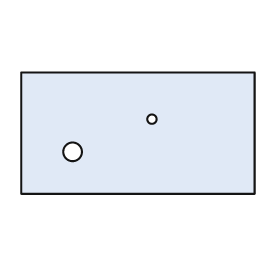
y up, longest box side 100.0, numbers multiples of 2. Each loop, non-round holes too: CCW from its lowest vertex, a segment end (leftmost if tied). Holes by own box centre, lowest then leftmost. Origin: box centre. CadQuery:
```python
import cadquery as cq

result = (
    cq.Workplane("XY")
    .moveTo(-50.0, -26.0)
    .lineTo(50.0, -26.0)
    .lineTo(50.0, 26.0)
    .lineTo(-50.0, 26.0)
    .close()
    .moveTo(-28.0, -8.0)
    .circle(4.0)
    .moveTo(6.0, 6.0)
    .circle(2.0)
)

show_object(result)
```